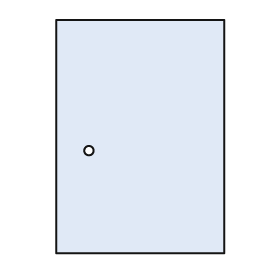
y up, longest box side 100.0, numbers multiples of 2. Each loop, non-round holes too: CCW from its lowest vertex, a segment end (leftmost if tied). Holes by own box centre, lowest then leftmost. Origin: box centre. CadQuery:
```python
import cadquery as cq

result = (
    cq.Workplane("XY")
    .moveTo(-36.0, -50.0)
    .lineTo(36.0, -50.0)
    .lineTo(36.0, 50.0)
    .lineTo(-36.0, 50.0)
    .close()
    .moveTo(-22.0, -6.0)
    .circle(2.0)
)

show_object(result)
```